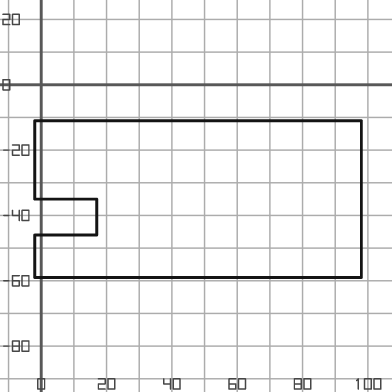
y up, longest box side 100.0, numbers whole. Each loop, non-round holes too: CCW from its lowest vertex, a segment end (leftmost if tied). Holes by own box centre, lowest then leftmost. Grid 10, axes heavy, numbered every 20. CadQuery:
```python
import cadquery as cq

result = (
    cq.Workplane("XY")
    .moveTo(-2.0, -59.0)
    .lineTo(98.0, -59.0)
    .lineTo(98.0, -11.0)
    .lineTo(-2.0, -11.0)
    .lineTo(-2.0, -35.0)
    .lineTo(17.0, -35.0)
    .lineTo(17.0, -46.0)
    .lineTo(-2.0, -46.0)
    .close()
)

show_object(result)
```